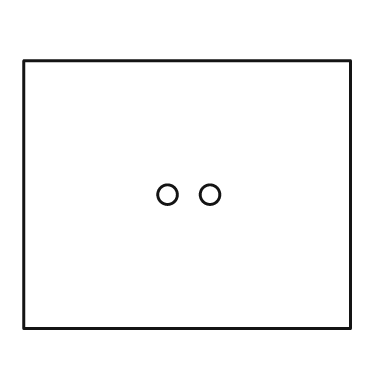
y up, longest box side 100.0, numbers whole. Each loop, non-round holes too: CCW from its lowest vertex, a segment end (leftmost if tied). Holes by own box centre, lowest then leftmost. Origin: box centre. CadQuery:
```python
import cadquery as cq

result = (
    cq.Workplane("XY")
    .moveTo(-50.0, -41.0)
    .lineTo(50.0, -41.0)
    .lineTo(50.0, 41.0)
    .lineTo(-50.0, 41.0)
    .close()
    .moveTo(-6.0, 0.0)
    .circle(3.0)
    .moveTo(7.0, 0.0)
    .circle(3.0)
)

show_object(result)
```